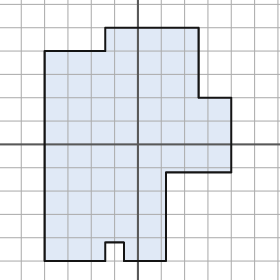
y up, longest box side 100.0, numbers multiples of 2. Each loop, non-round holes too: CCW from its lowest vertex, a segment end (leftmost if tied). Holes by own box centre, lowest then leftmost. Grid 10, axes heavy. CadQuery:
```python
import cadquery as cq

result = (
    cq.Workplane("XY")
    .moveTo(-40.0, -50.0)
    .lineTo(-14.0, -50.0)
    .lineTo(-14.0, -42.0)
    .lineTo(-6.0, -42.0)
    .lineTo(-6.0, -50.0)
    .lineTo(12.0, -50.0)
    .lineTo(12.0, -12.0)
    .lineTo(40.0, -12.0)
    .lineTo(40.0, 20.0)
    .lineTo(26.0, 20.0)
    .lineTo(26.0, 50.0)
    .lineTo(-14.0, 50.0)
    .lineTo(-14.0, 40.0)
    .lineTo(-40.0, 40.0)
    .close()
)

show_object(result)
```